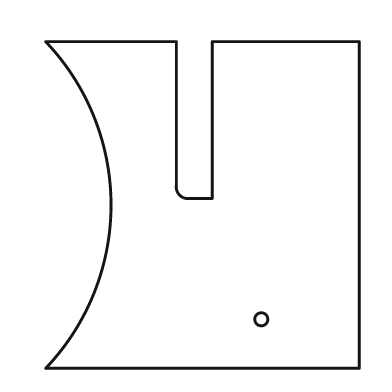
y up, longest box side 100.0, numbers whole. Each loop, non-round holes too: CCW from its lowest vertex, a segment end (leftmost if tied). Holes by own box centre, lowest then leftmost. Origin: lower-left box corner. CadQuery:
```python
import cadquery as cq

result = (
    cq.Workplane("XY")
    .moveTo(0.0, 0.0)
    .lineTo(96.0, 0.0)
    .lineTo(96.0, 100.0)
    .lineTo(51.0, 100.0)
    .lineTo(51.0, 52.0)
    .lineTo(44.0, 52.0)
    .threePointArc((41.0, 53.0), (40.0, 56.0))
    .lineTo(40.0, 100.0)
    .lineTo(0.0, 100.0)
    .threePointArc((20.0, 50.0), (0.0, 0.0))
    .close()
    .moveTo(66.0, 15.0)
    .circle(2.0)
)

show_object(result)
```